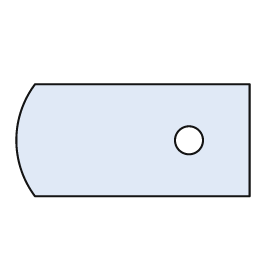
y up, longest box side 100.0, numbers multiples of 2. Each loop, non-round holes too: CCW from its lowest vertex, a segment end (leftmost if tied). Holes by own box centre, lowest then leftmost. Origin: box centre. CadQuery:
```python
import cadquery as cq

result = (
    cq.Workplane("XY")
    .moveTo(-42.0, -24.0)
    .lineTo(50.0, -24.0)
    .lineTo(50.0, 24.0)
    .lineTo(-42.0, 24.0)
    .threePointArc((-50.0, 0.0), (-42.0, -24.0))
    .close()
    .moveTo(24.0, 0.0)
    .circle(6.0)
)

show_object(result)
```